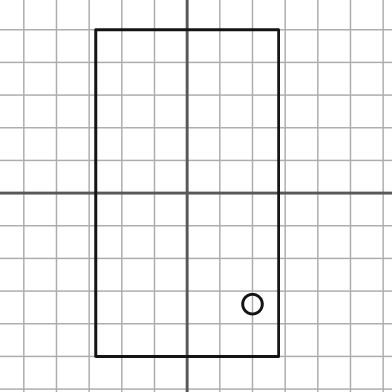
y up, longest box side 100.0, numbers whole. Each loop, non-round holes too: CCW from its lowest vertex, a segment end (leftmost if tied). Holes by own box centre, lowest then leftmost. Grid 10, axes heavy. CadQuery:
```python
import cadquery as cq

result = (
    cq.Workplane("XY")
    .moveTo(-28.0, -50.0)
    .lineTo(28.0, -50.0)
    .lineTo(28.0, 50.0)
    .lineTo(-28.0, 50.0)
    .close()
    .moveTo(20.0, -34.0)
    .circle(3.0)
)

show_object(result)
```